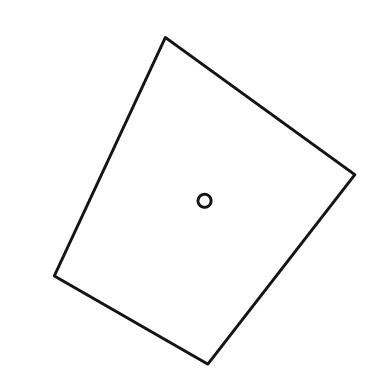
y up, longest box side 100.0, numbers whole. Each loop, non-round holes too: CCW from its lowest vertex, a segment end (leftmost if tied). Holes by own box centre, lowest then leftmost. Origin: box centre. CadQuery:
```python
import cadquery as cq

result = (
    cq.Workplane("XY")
    .moveTo(1.0, -50.0)
    .lineTo(46.0, 8.0)
    .lineTo(-12.0, 50.0)
    .lineTo(-46.0, -23.0)
    .close()
    .moveTo(0.0, 0.0)
    .circle(2.0)
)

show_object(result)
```